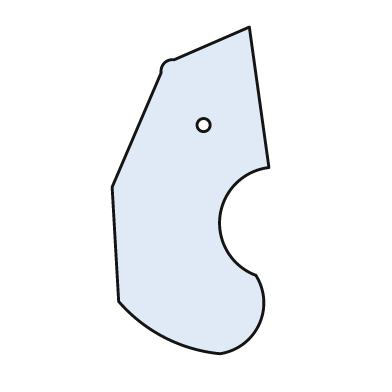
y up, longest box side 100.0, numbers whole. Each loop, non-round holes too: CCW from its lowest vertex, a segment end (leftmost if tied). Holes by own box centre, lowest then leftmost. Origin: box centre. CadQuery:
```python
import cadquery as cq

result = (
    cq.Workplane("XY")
    .moveTo(9.0, -50.0)
    .threePointArc((21.0, -41.0), (20.0, -26.0))
    .threePointArc((9.0, -8.0), (24.0, 7.0))
    .lineTo(18.0, 50.0)
    .lineTo(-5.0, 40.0)
    .threePointArc((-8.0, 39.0), (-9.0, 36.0))
    .lineTo(-24.0, 1.0)
    .lineTo(-22.0, -34.0)
    .threePointArc((-8.0, -45.0), (9.0, -50.0))
    .close()
    .moveTo(4.0, 20.0)
    .circle(2.0)
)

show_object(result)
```